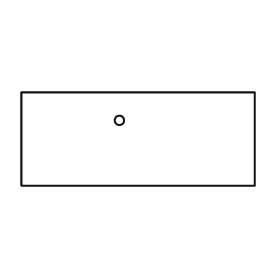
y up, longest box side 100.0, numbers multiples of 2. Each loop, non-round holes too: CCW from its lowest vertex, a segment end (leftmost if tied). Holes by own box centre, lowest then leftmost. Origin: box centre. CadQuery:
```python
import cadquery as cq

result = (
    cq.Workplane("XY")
    .moveTo(-50.0, -20.0)
    .lineTo(50.0, -20.0)
    .lineTo(50.0, 20.0)
    .lineTo(-50.0, 20.0)
    .close()
    .moveTo(-8.0, 8.0)
    .circle(2.0)
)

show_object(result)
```